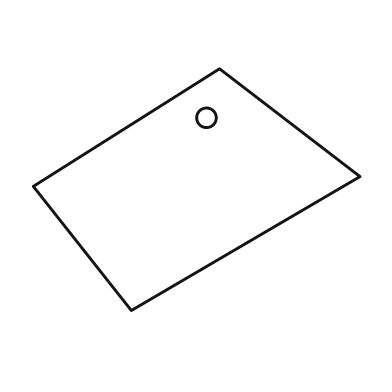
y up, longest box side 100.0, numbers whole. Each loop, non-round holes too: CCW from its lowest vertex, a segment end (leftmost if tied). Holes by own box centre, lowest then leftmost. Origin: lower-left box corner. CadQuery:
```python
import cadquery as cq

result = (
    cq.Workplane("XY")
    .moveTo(30.0, 0.0)
    .lineTo(100.0, 41.0)
    .lineTo(57.0, 74.0)
    .lineTo(0.0, 38.0)
    .close()
    .moveTo(53.0, 59.0)
    .circle(3.0)
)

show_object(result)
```